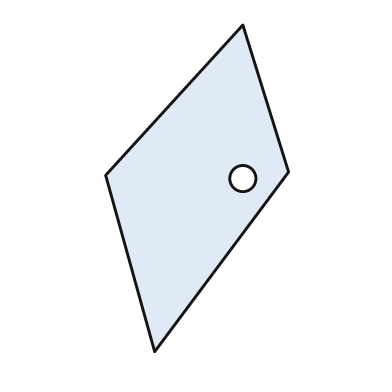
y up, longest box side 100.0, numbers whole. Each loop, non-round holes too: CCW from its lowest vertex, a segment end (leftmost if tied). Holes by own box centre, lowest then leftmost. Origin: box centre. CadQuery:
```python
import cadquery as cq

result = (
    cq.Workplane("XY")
    .moveTo(-13.0, -50.0)
    .lineTo(28.0, 5.0)
    .lineTo(14.0, 50.0)
    .lineTo(-28.0, 4.0)
    .close()
    .moveTo(14.0, 3.0)
    .circle(4.0)
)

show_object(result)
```